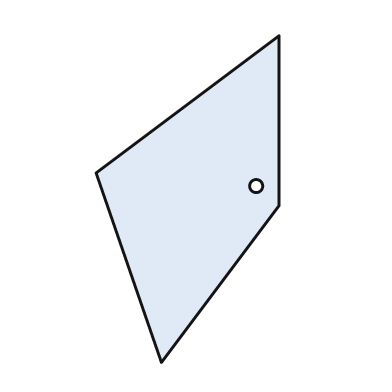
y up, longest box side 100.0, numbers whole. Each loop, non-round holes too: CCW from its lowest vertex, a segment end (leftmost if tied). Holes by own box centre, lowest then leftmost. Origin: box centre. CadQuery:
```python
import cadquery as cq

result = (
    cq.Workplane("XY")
    .moveTo(-8.0, -50.0)
    .lineTo(28.0, -2.0)
    .lineTo(28.0, 50.0)
    .lineTo(-28.0, 8.0)
    .close()
    .moveTo(21.0, 4.0)
    .circle(2.0)
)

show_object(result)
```